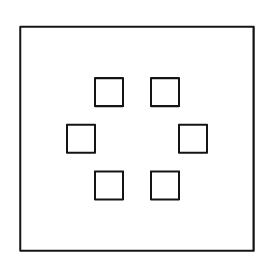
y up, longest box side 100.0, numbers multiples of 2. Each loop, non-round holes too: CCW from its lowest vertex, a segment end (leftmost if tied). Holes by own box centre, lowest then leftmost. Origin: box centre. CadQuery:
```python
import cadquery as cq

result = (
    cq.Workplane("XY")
    .moveTo(-50.0, -48.0)
    .lineTo(50.0, -48.0)
    .lineTo(50.0, 48.0)
    .lineTo(-50.0, 48.0)
    .close()
    .moveTo(-18.0, -26.0)
    .lineTo(-6.0, -26.0)
    .lineTo(-6.0, -14.0)
    .lineTo(-18.0, -14.0)
    .close()
    .moveTo(6.0, -26.0)
    .lineTo(18.0, -26.0)
    .lineTo(18.0, -14.0)
    .lineTo(6.0, -14.0)
    .close()
    .moveTo(-30.0, -6.0)
    .lineTo(-18.0, -6.0)
    .lineTo(-18.0, 6.0)
    .lineTo(-30.0, 6.0)
    .close()
    .moveTo(18.0, -6.0)
    .lineTo(30.0, -6.0)
    .lineTo(30.0, 6.0)
    .lineTo(18.0, 6.0)
    .close()
    .moveTo(-18.0, 14.0)
    .lineTo(-6.0, 14.0)
    .lineTo(-6.0, 26.0)
    .lineTo(-18.0, 26.0)
    .close()
    .moveTo(6.0, 14.0)
    .lineTo(18.0, 14.0)
    .lineTo(18.0, 26.0)
    .lineTo(6.0, 26.0)
    .close()
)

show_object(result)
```